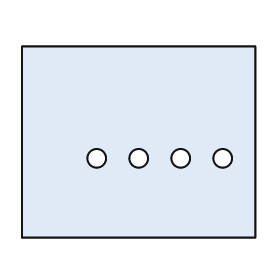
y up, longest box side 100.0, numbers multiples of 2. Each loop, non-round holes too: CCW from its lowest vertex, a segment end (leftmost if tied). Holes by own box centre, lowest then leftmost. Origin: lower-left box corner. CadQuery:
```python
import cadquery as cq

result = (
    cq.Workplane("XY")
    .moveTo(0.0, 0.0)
    .lineTo(100.0, 0.0)
    .lineTo(100.0, 82.0)
    .lineTo(0.0, 82.0)
    .close()
    .moveTo(32.0, 34.0)
    .circle(4.0)
    .moveTo(50.0, 34.0)
    .circle(4.0)
    .moveTo(68.0, 34.0)
    .circle(4.0)
    .moveTo(86.0, 34.0)
    .circle(4.0)
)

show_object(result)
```